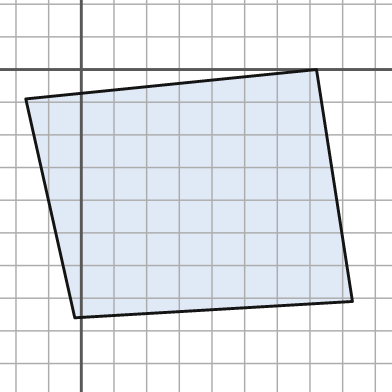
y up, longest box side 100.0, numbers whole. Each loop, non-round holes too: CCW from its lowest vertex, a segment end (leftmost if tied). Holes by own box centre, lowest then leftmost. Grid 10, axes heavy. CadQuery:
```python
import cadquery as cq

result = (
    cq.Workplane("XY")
    .moveTo(-2.0, -76.0)
    .lineTo(83.0, -71.0)
    .lineTo(72.0, 0.0)
    .lineTo(-17.0, -9.0)
    .close()
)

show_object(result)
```